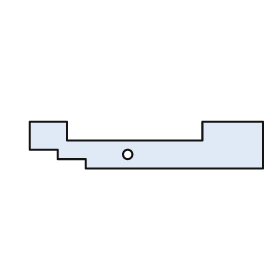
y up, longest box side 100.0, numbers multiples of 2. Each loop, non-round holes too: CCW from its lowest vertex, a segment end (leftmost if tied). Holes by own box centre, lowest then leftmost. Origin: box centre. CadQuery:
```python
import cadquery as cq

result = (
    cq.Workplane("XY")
    .moveTo(-26.0, -10.0)
    .lineTo(50.0, -10.0)
    .lineTo(50.0, 10.0)
    .lineTo(24.0, 10.0)
    .lineTo(24.0, 2.0)
    .lineTo(-34.0, 2.0)
    .lineTo(-34.0, 10.0)
    .lineTo(-50.0, 10.0)
    .lineTo(-50.0, -2.0)
    .lineTo(-38.0, -2.0)
    .lineTo(-38.0, -6.0)
    .lineTo(-26.0, -6.0)
    .close()
    .moveTo(-8.0, -4.0)
    .circle(2.0)
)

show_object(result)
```